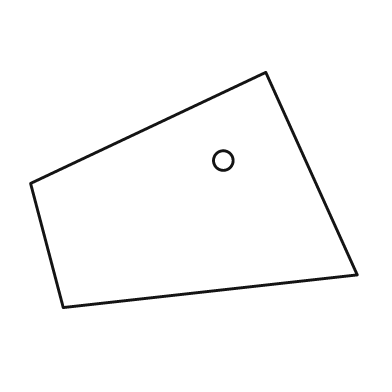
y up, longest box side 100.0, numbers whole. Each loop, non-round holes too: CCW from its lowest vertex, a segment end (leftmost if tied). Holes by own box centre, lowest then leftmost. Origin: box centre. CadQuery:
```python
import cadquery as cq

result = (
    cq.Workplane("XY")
    .moveTo(-40.0, -36.0)
    .lineTo(50.0, -26.0)
    .lineTo(22.0, 36.0)
    .lineTo(-50.0, 2.0)
    .close()
    .moveTo(9.0, 9.0)
    .circle(3.0)
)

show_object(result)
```